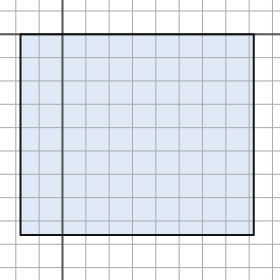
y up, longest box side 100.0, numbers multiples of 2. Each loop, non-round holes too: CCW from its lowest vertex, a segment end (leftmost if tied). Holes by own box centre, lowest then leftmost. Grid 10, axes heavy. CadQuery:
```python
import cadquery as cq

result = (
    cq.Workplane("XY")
    .moveTo(-18.0, -86.0)
    .lineTo(82.0, -86.0)
    .lineTo(82.0, 0.0)
    .lineTo(-18.0, 0.0)
    .close()
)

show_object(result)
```